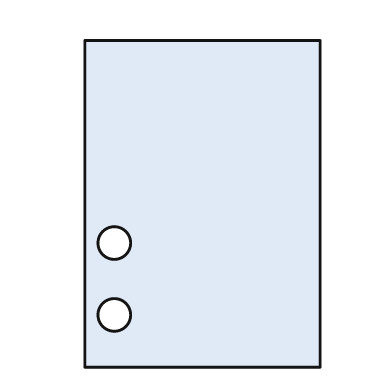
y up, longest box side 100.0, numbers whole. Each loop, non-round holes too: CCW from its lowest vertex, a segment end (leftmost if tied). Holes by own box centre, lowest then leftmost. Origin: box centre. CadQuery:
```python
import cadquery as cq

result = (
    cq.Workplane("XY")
    .moveTo(-36.0, -50.0)
    .lineTo(36.0, -50.0)
    .lineTo(36.0, 50.0)
    .lineTo(-36.0, 50.0)
    .close()
    .moveTo(-27.0, -34.0)
    .circle(5.0)
    .moveTo(-27.0, -12.0)
    .circle(5.0)
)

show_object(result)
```